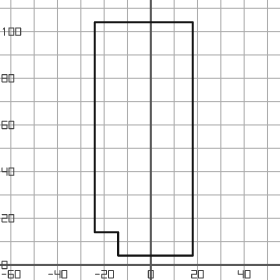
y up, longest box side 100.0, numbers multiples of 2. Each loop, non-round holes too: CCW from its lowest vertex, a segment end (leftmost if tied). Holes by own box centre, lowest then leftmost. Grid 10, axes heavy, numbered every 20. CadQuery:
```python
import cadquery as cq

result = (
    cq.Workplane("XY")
    .moveTo(-14.0, 4.0)
    .lineTo(18.0, 4.0)
    .lineTo(18.0, 104.0)
    .lineTo(-24.0, 104.0)
    .lineTo(-24.0, 14.0)
    .lineTo(-14.0, 14.0)
    .close()
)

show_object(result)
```